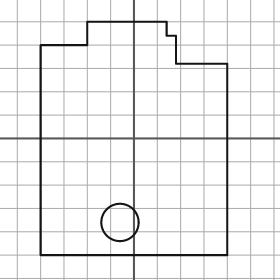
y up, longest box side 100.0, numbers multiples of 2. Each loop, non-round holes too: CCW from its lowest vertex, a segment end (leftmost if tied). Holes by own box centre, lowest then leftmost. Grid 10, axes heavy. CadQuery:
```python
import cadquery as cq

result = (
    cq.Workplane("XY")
    .moveTo(-40.0, -50.0)
    .lineTo(40.0, -50.0)
    .lineTo(40.0, 32.0)
    .lineTo(18.0, 32.0)
    .lineTo(18.0, 44.0)
    .lineTo(14.0, 44.0)
    .lineTo(14.0, 50.0)
    .lineTo(-20.0, 50.0)
    .lineTo(-20.0, 40.0)
    .lineTo(-40.0, 40.0)
    .close()
    .moveTo(-6.0, -36.0)
    .circle(8.0)
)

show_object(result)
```